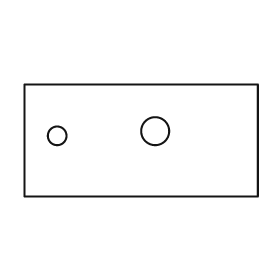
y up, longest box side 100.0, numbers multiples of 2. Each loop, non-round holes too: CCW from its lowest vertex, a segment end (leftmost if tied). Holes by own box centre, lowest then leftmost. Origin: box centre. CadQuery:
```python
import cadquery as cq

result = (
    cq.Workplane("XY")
    .moveTo(-50.0, -24.0)
    .lineTo(50.0, -24.0)
    .lineTo(50.0, 24.0)
    .lineTo(-50.0, 24.0)
    .close()
    .moveTo(-36.0, 2.0)
    .circle(4.0)
    .moveTo(6.0, 4.0)
    .circle(6.0)
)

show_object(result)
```